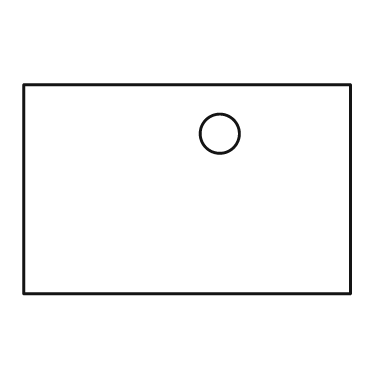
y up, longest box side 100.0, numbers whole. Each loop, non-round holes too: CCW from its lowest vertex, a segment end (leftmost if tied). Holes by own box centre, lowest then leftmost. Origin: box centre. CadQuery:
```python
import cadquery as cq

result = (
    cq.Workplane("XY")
    .moveTo(-50.0, -32.0)
    .lineTo(50.0, -32.0)
    .lineTo(50.0, 32.0)
    .lineTo(-50.0, 32.0)
    .close()
    .moveTo(10.0, 17.0)
    .circle(6.0)
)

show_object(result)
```